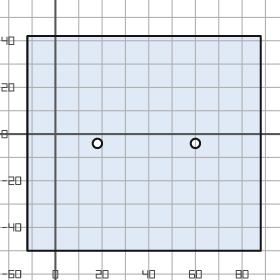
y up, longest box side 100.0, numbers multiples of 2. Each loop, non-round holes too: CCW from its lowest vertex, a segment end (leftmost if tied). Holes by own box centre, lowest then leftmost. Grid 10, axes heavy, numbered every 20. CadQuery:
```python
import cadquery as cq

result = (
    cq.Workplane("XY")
    .moveTo(-12.0, -50.0)
    .lineTo(88.0, -50.0)
    .lineTo(88.0, 42.0)
    .lineTo(-12.0, 42.0)
    .close()
    .moveTo(18.0, -4.0)
    .circle(2.0)
    .moveTo(60.0, -4.0)
    .circle(2.0)
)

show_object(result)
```